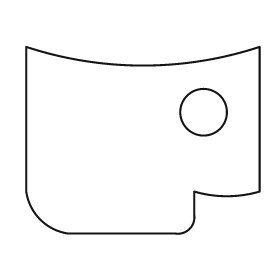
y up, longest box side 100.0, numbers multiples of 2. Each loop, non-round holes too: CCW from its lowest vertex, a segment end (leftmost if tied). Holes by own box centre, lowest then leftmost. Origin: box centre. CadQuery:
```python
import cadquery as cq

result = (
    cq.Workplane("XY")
    .moveTo(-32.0, -40.0)
    .lineTo(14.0, -40.0)
    .threePointArc((20.0, -38.0), (22.0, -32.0))
    .lineTo(22.0, -22.0)
    .threePointArc((36.0, -24.0), (50.0, -22.0))
    .lineTo(50.0, 40.0)
    .threePointArc((0.0, 32.0), (-50.0, 40.0))
    .lineTo(-50.0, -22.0)
    .threePointArc((-44.0, -34.0), (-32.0, -40.0))
    .close()
    .moveTo(26.0, 12.0)
    .circle(10.0)
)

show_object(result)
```